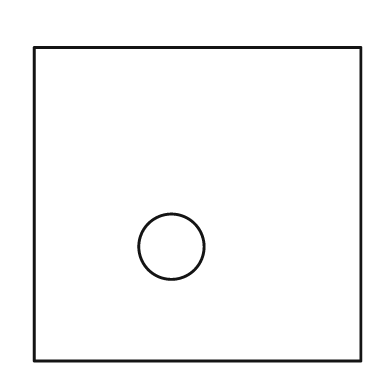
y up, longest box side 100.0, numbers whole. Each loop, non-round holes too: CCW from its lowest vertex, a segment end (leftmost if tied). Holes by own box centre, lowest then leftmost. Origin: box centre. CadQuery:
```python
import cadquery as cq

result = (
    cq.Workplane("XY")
    .moveTo(-50.0, -48.0)
    .lineTo(50.0, -48.0)
    .lineTo(50.0, 48.0)
    .lineTo(-50.0, 48.0)
    .close()
    .moveTo(-8.0, -13.0)
    .circle(10.0)
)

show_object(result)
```